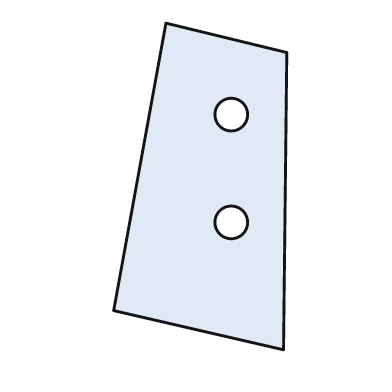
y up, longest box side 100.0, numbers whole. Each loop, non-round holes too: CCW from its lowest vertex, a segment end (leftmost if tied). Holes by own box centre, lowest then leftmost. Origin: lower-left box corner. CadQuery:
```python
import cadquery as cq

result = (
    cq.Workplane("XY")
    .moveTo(52.0, 0.0)
    .lineTo(53.0, 91.0)
    .lineTo(16.0, 100.0)
    .lineTo(0.0, 12.0)
    .close()
    .moveTo(36.0, 39.0)
    .circle(5.0)
    .moveTo(36.0, 72.0)
    .circle(5.0)
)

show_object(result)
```